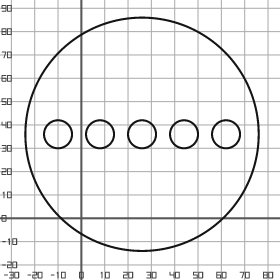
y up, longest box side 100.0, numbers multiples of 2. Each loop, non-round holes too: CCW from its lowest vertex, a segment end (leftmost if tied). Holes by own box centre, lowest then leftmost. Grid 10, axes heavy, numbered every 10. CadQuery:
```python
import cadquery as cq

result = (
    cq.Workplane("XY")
    .moveTo(26.0, 36.0)
    .circle(50.0)
    .moveTo(-10.0, 36.0)
    .circle(6.0)
    .moveTo(8.0, 36.0)
    .circle(6.0)
    .moveTo(26.0, 36.0)
    .circle(6.0)
    .moveTo(44.0, 36.0)
    .circle(6.0)
    .moveTo(62.0, 36.0)
    .circle(6.0)
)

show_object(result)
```